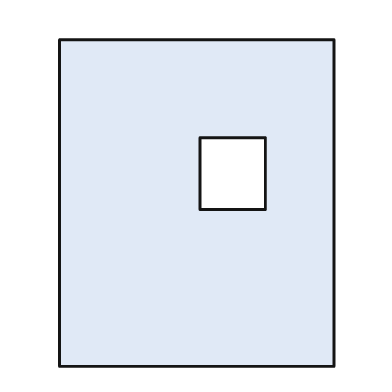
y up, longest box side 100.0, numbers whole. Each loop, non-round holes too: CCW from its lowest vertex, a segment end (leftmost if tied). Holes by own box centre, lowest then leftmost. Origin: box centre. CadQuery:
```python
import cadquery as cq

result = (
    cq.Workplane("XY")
    .moveTo(-42.0, -50.0)
    .lineTo(42.0, -50.0)
    .lineTo(42.0, 50.0)
    .lineTo(-42.0, 50.0)
    .close()
    .moveTo(1.0, -2.0)
    .lineTo(21.0, -2.0)
    .lineTo(21.0, 20.0)
    .lineTo(1.0, 20.0)
    .close()
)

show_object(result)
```